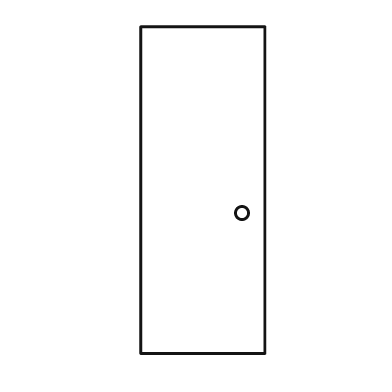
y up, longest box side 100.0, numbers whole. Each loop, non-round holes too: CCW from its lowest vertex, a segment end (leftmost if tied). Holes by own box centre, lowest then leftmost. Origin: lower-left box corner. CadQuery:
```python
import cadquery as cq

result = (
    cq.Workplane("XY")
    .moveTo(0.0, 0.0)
    .lineTo(38.0, 0.0)
    .lineTo(38.0, 100.0)
    .lineTo(0.0, 100.0)
    .close()
    .moveTo(31.0, 43.0)
    .circle(2.0)
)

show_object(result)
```